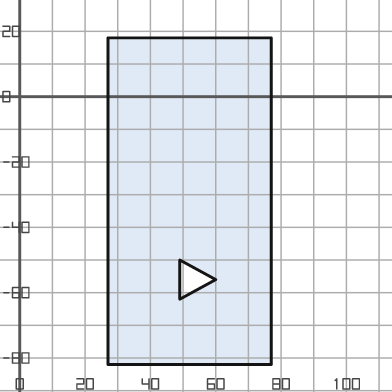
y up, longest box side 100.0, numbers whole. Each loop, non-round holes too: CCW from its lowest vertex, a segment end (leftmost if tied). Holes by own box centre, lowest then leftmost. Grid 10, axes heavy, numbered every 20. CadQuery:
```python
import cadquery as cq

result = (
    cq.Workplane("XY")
    .moveTo(27.0, -82.0)
    .lineTo(77.0, -82.0)
    .lineTo(77.0, 18.0)
    .lineTo(27.0, 18.0)
    .close()
    .moveTo(49.0, -62.0)
    .lineTo(60.0, -56.0)
    .lineTo(49.0, -50.0)
    .close()
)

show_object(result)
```